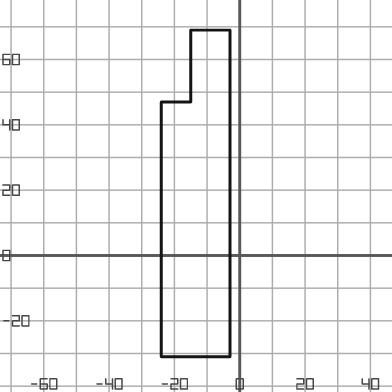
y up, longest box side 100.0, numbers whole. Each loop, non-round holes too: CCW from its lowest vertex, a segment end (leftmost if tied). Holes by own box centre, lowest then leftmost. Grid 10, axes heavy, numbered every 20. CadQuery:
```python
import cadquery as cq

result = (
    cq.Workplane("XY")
    .moveTo(-24.0, -31.0)
    .lineTo(-3.0, -31.0)
    .lineTo(-3.0, 69.0)
    .lineTo(-15.0, 69.0)
    .lineTo(-15.0, 47.0)
    .lineTo(-24.0, 47.0)
    .close()
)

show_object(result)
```